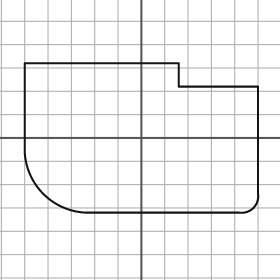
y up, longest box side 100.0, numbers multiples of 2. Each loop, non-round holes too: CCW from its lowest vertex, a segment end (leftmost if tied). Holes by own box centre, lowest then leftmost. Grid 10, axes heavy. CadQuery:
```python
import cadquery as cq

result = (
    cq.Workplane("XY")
    .moveTo(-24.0, -32.0)
    .lineTo(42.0, -32.0)
    .threePointArc((48.0, -30.0), (50.0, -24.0))
    .lineTo(50.0, 22.0)
    .lineTo(16.0, 22.0)
    .lineTo(16.0, 32.0)
    .lineTo(-50.0, 32.0)
    .lineTo(-50.0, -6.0)
    .threePointArc((-42.0, -24.0), (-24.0, -32.0))
    .close()
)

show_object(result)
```